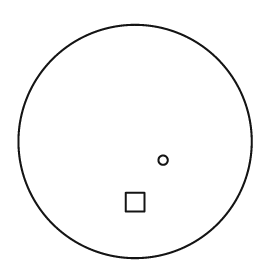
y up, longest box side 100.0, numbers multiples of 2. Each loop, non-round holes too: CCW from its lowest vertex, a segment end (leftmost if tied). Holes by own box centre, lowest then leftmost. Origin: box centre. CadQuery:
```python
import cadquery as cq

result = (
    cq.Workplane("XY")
    .moveTo(0.0, 0.0)
    .circle(50.0)
    .moveTo(-4.0, -30.0)
    .lineTo(4.0, -30.0)
    .lineTo(4.0, -22.0)
    .lineTo(-4.0, -22.0)
    .close()
    .moveTo(12.0, -8.0)
    .circle(2.0)
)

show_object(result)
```